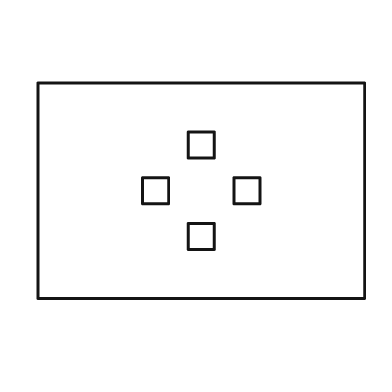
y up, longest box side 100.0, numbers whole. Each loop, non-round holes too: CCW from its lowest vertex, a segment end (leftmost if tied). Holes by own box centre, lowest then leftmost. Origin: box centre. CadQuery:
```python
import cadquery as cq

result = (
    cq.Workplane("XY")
    .moveTo(-50.0, -33.0)
    .lineTo(50.0, -33.0)
    .lineTo(50.0, 33.0)
    .lineTo(-50.0, 33.0)
    .close()
    .moveTo(-4.0, -18.0)
    .lineTo(4.0, -18.0)
    .lineTo(4.0, -10.0)
    .lineTo(-4.0, -10.0)
    .close()
    .moveTo(-18.0, -4.0)
    .lineTo(-10.0, -4.0)
    .lineTo(-10.0, 4.0)
    .lineTo(-18.0, 4.0)
    .close()
    .moveTo(10.0, -4.0)
    .lineTo(18.0, -4.0)
    .lineTo(18.0, 4.0)
    .lineTo(10.0, 4.0)
    .close()
    .moveTo(-4.0, 10.0)
    .lineTo(4.0, 10.0)
    .lineTo(4.0, 18.0)
    .lineTo(-4.0, 18.0)
    .close()
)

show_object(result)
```